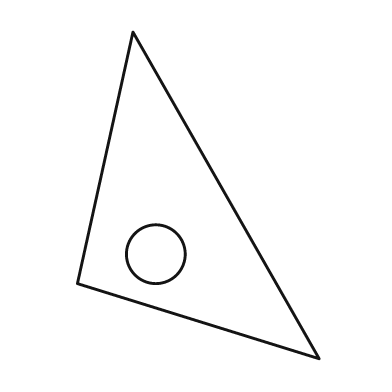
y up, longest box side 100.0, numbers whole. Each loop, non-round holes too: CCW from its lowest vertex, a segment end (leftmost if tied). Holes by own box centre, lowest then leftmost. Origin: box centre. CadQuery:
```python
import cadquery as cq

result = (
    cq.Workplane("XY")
    .moveTo(37.0, -50.0)
    .lineTo(-20.0, 50.0)
    .lineTo(-37.0, -27.0)
    .close()
    .moveTo(-13.0, -18.0)
    .circle(9.0)
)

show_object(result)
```